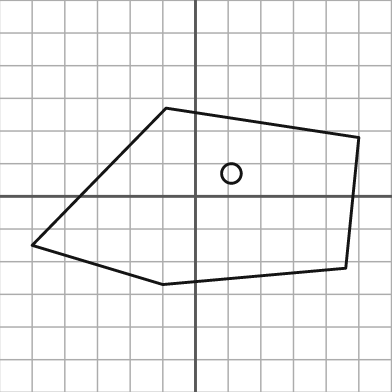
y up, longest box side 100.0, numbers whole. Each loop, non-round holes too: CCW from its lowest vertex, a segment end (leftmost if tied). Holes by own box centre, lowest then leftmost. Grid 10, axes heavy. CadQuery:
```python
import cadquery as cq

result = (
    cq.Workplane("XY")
    .moveTo(-10.0, -27.0)
    .lineTo(46.0, -22.0)
    .lineTo(50.0, 18.0)
    .lineTo(-9.0, 27.0)
    .lineTo(-50.0, -15.0)
    .close()
    .moveTo(11.0, 7.0)
    .circle(3.0)
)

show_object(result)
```